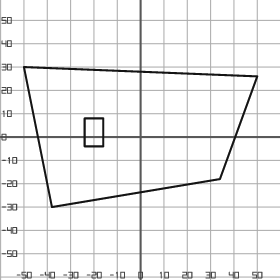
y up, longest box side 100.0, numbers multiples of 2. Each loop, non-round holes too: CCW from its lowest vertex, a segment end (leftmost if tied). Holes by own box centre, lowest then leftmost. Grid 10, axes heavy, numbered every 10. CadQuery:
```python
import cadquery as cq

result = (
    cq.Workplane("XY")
    .moveTo(-38.0, -30.0)
    .lineTo(34.0, -18.0)
    .lineTo(50.0, 26.0)
    .lineTo(-50.0, 30.0)
    .close()
    .moveTo(-24.0, -4.0)
    .lineTo(-16.0, -4.0)
    .lineTo(-16.0, 8.0)
    .lineTo(-24.0, 8.0)
    .close()
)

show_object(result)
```